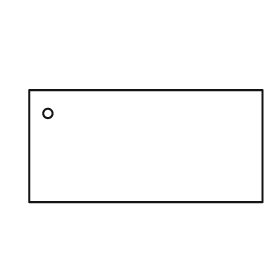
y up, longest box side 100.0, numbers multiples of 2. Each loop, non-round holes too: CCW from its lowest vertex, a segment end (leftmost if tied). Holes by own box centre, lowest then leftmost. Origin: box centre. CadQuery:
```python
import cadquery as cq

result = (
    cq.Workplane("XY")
    .moveTo(-50.0, -24.0)
    .lineTo(50.0, -24.0)
    .lineTo(50.0, 24.0)
    .lineTo(-50.0, 24.0)
    .close()
    .moveTo(-42.0, 14.0)
    .circle(2.0)
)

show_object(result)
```